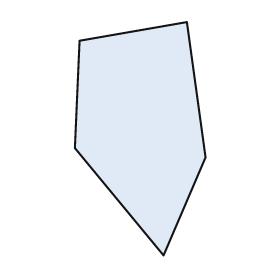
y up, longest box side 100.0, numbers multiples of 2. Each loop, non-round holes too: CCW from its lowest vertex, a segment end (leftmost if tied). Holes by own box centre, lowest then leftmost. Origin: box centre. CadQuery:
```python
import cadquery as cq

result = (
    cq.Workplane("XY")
    .moveTo(10.0, -50.0)
    .lineTo(28.0, -8.0)
    .lineTo(20.0, 50.0)
    .lineTo(-26.0, 42.0)
    .lineTo(-28.0, -4.0)
    .close()
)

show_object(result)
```